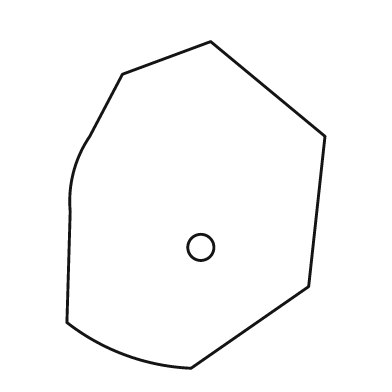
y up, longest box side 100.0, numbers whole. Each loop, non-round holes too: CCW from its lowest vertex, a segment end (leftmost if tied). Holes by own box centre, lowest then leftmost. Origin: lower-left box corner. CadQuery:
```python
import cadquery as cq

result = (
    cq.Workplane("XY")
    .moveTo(38.0, 0.0)
    .lineTo(74.0, 25.0)
    .lineTo(79.0, 71.0)
    .lineTo(44.0, 100.0)
    .lineTo(17.0, 90.0)
    .lineTo(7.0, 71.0)
    .threePointArc((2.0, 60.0), (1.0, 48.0))
    .lineTo(0.0, 14.0)
    .threePointArc((18.0, 4.0), (38.0, 0.0))
    .close()
    .moveTo(41.0, 37.0)
    .circle(4.0)
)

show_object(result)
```